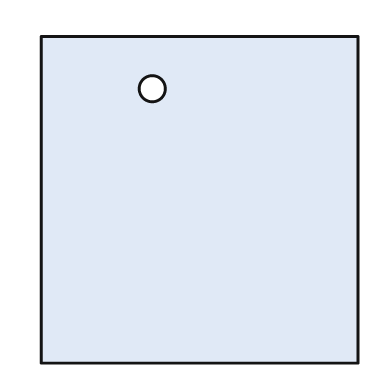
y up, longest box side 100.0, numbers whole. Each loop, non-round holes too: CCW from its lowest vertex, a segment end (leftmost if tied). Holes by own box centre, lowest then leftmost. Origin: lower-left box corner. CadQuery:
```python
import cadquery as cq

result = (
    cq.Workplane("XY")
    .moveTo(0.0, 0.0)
    .lineTo(97.0, 0.0)
    .lineTo(97.0, 100.0)
    .lineTo(0.0, 100.0)
    .close()
    .moveTo(34.0, 84.0)
    .circle(4.0)
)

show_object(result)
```